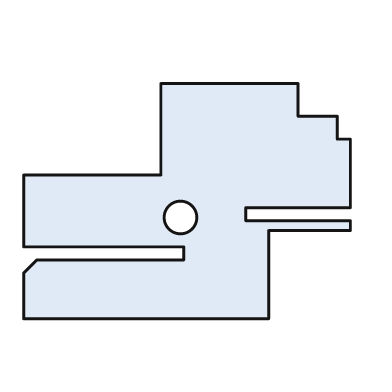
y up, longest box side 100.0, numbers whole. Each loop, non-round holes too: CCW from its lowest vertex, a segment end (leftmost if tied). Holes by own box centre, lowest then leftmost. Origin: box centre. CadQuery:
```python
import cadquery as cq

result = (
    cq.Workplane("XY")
    .moveTo(-50.0, -36.0)
    .lineTo(25.0, -36.0)
    .lineTo(25.0, -9.0)
    .lineTo(50.0, -9.0)
    .lineTo(50.0, -6.0)
    .lineTo(18.0, -6.0)
    .lineTo(18.0, -2.0)
    .lineTo(50.0, -2.0)
    .lineTo(50.0, 19.0)
    .lineTo(46.0, 19.0)
    .lineTo(46.0, 26.0)
    .lineTo(34.0, 26.0)
    .lineTo(34.0, 36.0)
    .lineTo(-8.0, 36.0)
    .lineTo(-8.0, 8.0)
    .lineTo(-50.0, 8.0)
    .lineTo(-50.0, -14.0)
    .lineTo(-1.0, -14.0)
    .lineTo(-1.0, -18.0)
    .lineTo(-46.0, -18.0)
    .lineTo(-50.0, -22.0)
    .close()
    .moveTo(-2.0, -5.0)
    .circle(5.0)
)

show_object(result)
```